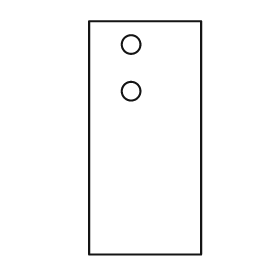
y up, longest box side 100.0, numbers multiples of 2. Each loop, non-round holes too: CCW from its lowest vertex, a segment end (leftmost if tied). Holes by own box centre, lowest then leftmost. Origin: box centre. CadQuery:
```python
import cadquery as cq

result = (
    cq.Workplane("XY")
    .moveTo(-24.0, -50.0)
    .lineTo(24.0, -50.0)
    .lineTo(24.0, 50.0)
    .lineTo(-24.0, 50.0)
    .close()
    .moveTo(-6.0, 20.0)
    .circle(4.0)
    .moveTo(-6.0, 40.0)
    .circle(4.0)
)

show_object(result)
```